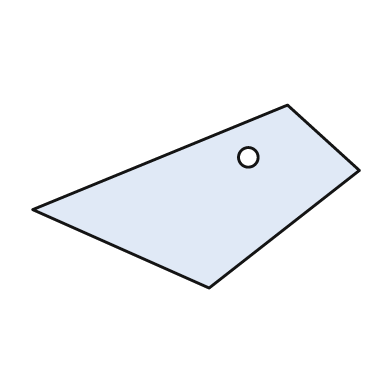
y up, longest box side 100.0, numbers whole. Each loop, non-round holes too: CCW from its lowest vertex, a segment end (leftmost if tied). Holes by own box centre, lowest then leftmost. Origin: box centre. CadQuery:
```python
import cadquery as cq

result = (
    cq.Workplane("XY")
    .moveTo(4.0, -28.0)
    .lineTo(50.0, 8.0)
    .lineTo(28.0, 28.0)
    .lineTo(-50.0, -4.0)
    .close()
    .moveTo(16.0, 12.0)
    .circle(3.0)
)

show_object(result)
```